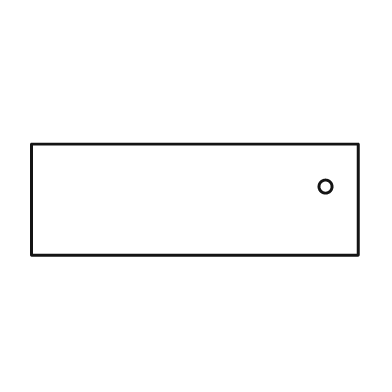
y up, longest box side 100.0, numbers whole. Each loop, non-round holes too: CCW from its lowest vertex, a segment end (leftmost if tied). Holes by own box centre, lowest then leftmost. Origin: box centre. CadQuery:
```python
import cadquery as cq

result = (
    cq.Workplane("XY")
    .moveTo(-50.0, -17.0)
    .lineTo(50.0, -17.0)
    .lineTo(50.0, 17.0)
    .lineTo(-50.0, 17.0)
    .close()
    .moveTo(40.0, 4.0)
    .circle(2.0)
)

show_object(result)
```